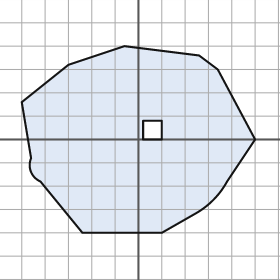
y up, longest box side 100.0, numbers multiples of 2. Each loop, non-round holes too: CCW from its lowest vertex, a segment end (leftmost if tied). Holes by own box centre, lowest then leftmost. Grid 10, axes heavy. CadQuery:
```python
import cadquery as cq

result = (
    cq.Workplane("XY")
    .moveTo(-24.0, -40.0)
    .lineTo(10.0, -40.0)
    .lineTo(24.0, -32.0)
    .threePointArc((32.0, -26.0), (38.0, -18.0))
    .lineTo(50.0, 0.0)
    .lineTo(34.0, 30.0)
    .lineTo(26.0, 36.0)
    .lineTo(-6.0, 40.0)
    .lineTo(-30.0, 32.0)
    .lineTo(-50.0, 16.0)
    .lineTo(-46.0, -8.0)
    .threePointArc((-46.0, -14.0), (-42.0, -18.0))
    .close()
    .moveTo(2.0, 0.0)
    .lineTo(10.0, 0.0)
    .lineTo(10.0, 8.0)
    .lineTo(2.0, 8.0)
    .close()
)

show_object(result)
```